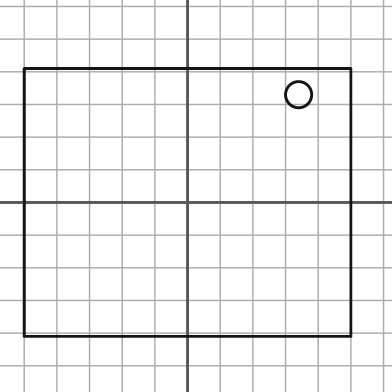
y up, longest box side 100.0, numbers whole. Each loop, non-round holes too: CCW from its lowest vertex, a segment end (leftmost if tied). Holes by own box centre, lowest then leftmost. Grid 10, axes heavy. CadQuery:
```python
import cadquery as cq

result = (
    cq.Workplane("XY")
    .moveTo(-50.0, -41.0)
    .lineTo(50.0, -41.0)
    .lineTo(50.0, 41.0)
    .lineTo(-50.0, 41.0)
    .close()
    .moveTo(34.0, 33.0)
    .circle(4.0)
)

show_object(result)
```